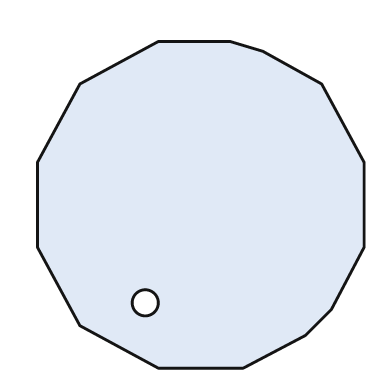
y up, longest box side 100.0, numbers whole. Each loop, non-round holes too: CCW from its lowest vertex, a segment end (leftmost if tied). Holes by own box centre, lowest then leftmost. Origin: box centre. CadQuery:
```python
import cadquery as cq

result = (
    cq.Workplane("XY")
    .moveTo(-13.0, -50.0)
    .lineTo(13.0, -50.0)
    .lineTo(32.0, -40.0)
    .lineTo(40.0, -32.0)
    .lineTo(50.0, -13.0)
    .lineTo(50.0, 13.0)
    .lineTo(37.0, 37.0)
    .lineTo(19.0, 47.0)
    .lineTo(9.0, 50.0)
    .lineTo(-13.0, 50.0)
    .lineTo(-37.0, 37.0)
    .lineTo(-50.0, 13.0)
    .lineTo(-50.0, -13.0)
    .lineTo(-37.0, -37.0)
    .close()
    .moveTo(-17.0, -30.0)
    .circle(4.0)
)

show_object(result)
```